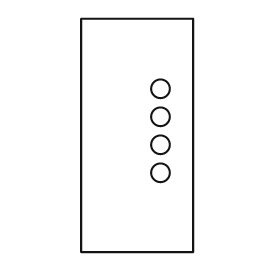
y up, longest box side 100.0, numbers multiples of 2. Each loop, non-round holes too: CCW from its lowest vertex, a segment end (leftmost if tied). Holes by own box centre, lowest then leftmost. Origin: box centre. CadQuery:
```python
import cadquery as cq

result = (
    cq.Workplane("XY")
    .moveTo(-24.0, -50.0)
    .lineTo(24.0, -50.0)
    .lineTo(24.0, 50.0)
    .lineTo(-24.0, 50.0)
    .close()
    .moveTo(10.0, -16.0)
    .circle(4.0)
    .moveTo(10.0, -4.0)
    .circle(4.0)
    .moveTo(10.0, 8.0)
    .circle(4.0)
    .moveTo(10.0, 20.0)
    .circle(4.0)
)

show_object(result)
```